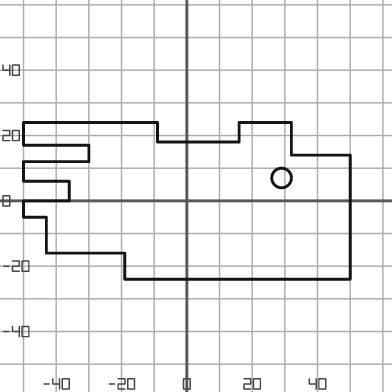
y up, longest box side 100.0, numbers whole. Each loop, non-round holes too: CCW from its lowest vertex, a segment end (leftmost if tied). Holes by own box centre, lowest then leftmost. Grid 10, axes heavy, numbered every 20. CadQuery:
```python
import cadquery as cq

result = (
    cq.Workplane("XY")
    .moveTo(-19.0, -24.0)
    .lineTo(50.0, -24.0)
    .lineTo(50.0, 14.0)
    .lineTo(32.0, 14.0)
    .lineTo(32.0, 24.0)
    .lineTo(16.0, 24.0)
    .lineTo(16.0, 18.0)
    .lineTo(-9.0, 18.0)
    .lineTo(-9.0, 24.0)
    .lineTo(-50.0, 24.0)
    .lineTo(-50.0, 17.0)
    .lineTo(-30.0, 17.0)
    .lineTo(-30.0, 12.0)
    .lineTo(-50.0, 12.0)
    .lineTo(-50.0, 6.0)
    .lineTo(-36.0, 6.0)
    .lineTo(-36.0, 0.0)
    .lineTo(-50.0, 0.0)
    .lineTo(-50.0, -5.0)
    .lineTo(-43.0, -5.0)
    .lineTo(-43.0, -16.0)
    .lineTo(-19.0, -16.0)
    .close()
    .moveTo(29.0, 7.0)
    .circle(3.0)
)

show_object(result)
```